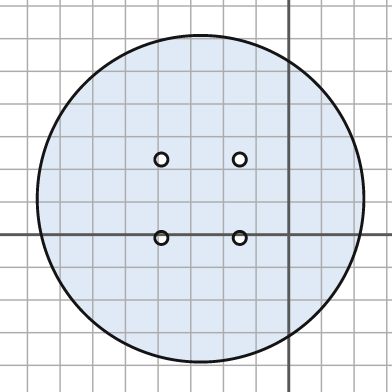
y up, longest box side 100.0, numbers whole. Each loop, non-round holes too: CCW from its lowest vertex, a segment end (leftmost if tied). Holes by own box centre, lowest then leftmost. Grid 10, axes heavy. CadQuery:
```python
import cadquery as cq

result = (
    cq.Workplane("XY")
    .moveTo(-27.0, 11.0)
    .circle(50.0)
    .moveTo(-39.0, -1.0)
    .circle(2.0)
    .moveTo(-15.0, -1.0)
    .circle(2.0)
    .moveTo(-39.0, 23.0)
    .circle(2.0)
    .moveTo(-15.0, 23.0)
    .circle(2.0)
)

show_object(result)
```